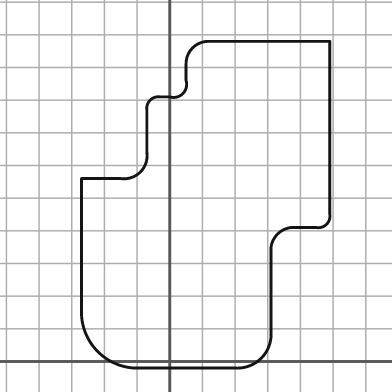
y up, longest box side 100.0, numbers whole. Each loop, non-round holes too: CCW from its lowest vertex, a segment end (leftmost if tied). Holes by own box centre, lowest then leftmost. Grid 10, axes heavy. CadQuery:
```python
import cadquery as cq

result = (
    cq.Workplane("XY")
    .moveTo(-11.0, -2.0)
    .lineTo(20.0, -2.0)
    .threePointArc((28.0, 1.0), (31.0, 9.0))
    .lineTo(31.0, 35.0)
    .threePointArc((33.0, 39.0), (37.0, 41.0))
    .lineTo(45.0, 41.0)
    .threePointArc((48.0, 42.0), (49.0, 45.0))
    .lineTo(49.0, 98.0)
    .lineTo(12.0, 98.0)
    .threePointArc((7.0, 96.0), (5.0, 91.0))
    .lineTo(5.0, 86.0)
    .threePointArc((4.0, 82.0), (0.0, 81.0))
    .lineTo(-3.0, 81.0)
    .threePointArc((-6.0, 80.0), (-7.0, 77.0))
    .lineTo(-7.0, 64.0)
    .threePointArc((-9.0, 58.0), (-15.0, 56.0))
    .lineTo(-27.0, 56.0)
    .lineTo(-27.0, 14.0)
    .threePointArc((-22.0, 3.0), (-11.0, -2.0))
    .close()
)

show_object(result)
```